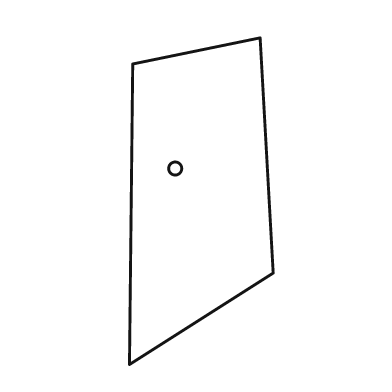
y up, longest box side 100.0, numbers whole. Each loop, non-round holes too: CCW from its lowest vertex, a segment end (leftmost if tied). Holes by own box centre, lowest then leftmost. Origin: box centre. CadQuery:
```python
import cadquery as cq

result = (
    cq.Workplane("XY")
    .moveTo(-22.0, -50.0)
    .lineTo(22.0, -22.0)
    .lineTo(18.0, 50.0)
    .lineTo(-21.0, 42.0)
    .close()
    .moveTo(-8.0, 10.0)
    .circle(2.0)
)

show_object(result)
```